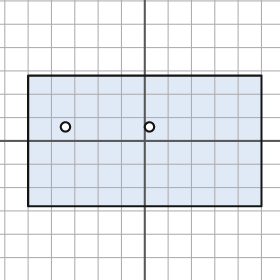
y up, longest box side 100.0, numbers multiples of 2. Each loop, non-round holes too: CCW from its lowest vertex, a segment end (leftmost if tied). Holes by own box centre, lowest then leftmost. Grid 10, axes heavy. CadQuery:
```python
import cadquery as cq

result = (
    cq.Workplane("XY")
    .moveTo(-50.0, -28.0)
    .lineTo(50.0, -28.0)
    .lineTo(50.0, 28.0)
    .lineTo(-50.0, 28.0)
    .close()
    .moveTo(-34.0, 6.0)
    .circle(2.0)
    .moveTo(2.0, 6.0)
    .circle(2.0)
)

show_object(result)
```